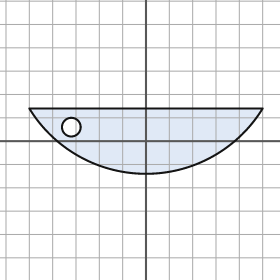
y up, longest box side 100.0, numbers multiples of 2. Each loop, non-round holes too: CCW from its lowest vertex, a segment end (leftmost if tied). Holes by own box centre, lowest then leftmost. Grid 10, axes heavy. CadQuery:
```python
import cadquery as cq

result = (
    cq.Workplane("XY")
    .moveTo(-50.0, 14.0)
    .threePointArc((0.0, -14.0), (50.0, 14.0))
    .close()
    .moveTo(-32.0, 6.0)
    .circle(4.0)
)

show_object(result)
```